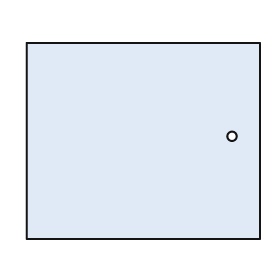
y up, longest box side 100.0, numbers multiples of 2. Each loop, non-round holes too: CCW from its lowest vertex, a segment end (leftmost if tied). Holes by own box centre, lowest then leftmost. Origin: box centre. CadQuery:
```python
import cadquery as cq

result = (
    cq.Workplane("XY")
    .moveTo(-50.0, -42.0)
    .lineTo(50.0, -42.0)
    .lineTo(50.0, 42.0)
    .lineTo(-50.0, 42.0)
    .close()
    .moveTo(38.0, 2.0)
    .circle(2.0)
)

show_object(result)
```